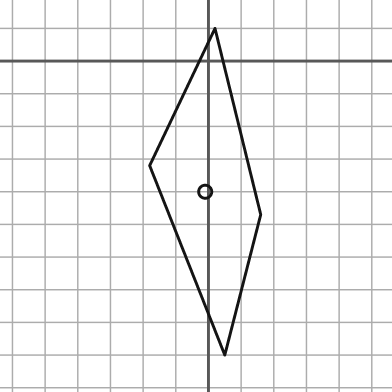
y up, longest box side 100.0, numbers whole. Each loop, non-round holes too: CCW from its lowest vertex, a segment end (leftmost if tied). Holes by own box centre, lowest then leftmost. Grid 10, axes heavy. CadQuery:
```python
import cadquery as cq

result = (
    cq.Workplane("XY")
    .moveTo(5.0, -90.0)
    .lineTo(16.0, -47.0)
    .lineTo(2.0, 10.0)
    .lineTo(-18.0, -32.0)
    .close()
    .moveTo(-1.0, -40.0)
    .circle(2.0)
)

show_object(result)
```